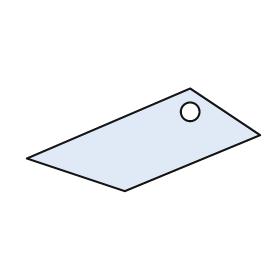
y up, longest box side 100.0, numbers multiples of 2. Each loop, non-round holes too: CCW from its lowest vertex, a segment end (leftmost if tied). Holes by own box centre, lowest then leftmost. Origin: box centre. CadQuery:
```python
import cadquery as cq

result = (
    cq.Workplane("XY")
    .moveTo(-8.0, -22.0)
    .lineTo(50.0, 2.0)
    .lineTo(20.0, 22.0)
    .lineTo(-50.0, -8.0)
    .close()
    .moveTo(20.0, 12.0)
    .circle(4.0)
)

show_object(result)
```